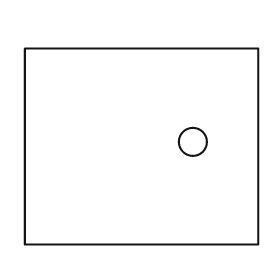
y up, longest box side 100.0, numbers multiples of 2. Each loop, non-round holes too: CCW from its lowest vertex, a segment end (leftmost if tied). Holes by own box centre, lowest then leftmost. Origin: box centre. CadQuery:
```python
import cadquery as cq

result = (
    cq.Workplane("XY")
    .moveTo(-50.0, -42.0)
    .lineTo(50.0, -42.0)
    .lineTo(50.0, 42.0)
    .lineTo(-50.0, 42.0)
    .close()
    .moveTo(22.0, 2.0)
    .circle(6.0)
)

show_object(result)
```